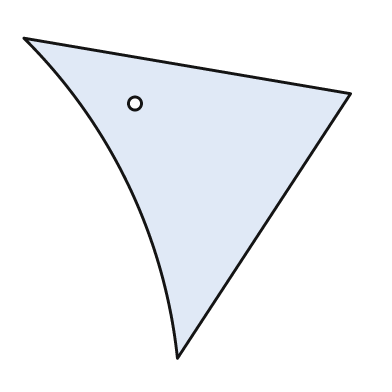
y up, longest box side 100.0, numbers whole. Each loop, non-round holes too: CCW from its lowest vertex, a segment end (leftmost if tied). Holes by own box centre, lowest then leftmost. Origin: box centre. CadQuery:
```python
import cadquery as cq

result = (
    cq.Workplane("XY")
    .moveTo(-3.0, -49.0)
    .lineTo(50.0, 32.0)
    .lineTo(-50.0, 49.0)
    .threePointArc((-18.0, 4.0), (-3.0, -49.0))
    .close()
    .moveTo(-16.0, 29.0)
    .circle(2.0)
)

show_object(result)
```